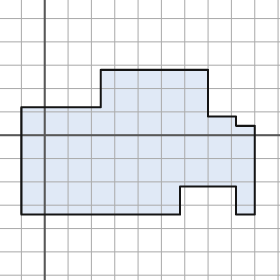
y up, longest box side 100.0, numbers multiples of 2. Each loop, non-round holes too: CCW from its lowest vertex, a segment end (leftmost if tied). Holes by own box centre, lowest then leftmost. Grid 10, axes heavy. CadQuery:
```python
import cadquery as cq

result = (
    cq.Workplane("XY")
    .moveTo(-10.0, -34.0)
    .lineTo(58.0, -34.0)
    .lineTo(58.0, -22.0)
    .lineTo(82.0, -22.0)
    .lineTo(82.0, -34.0)
    .lineTo(90.0, -34.0)
    .lineTo(90.0, 4.0)
    .lineTo(82.0, 4.0)
    .lineTo(82.0, 8.0)
    .lineTo(70.0, 8.0)
    .lineTo(70.0, 28.0)
    .lineTo(24.0, 28.0)
    .lineTo(24.0, 12.0)
    .lineTo(-10.0, 12.0)
    .close()
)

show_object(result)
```